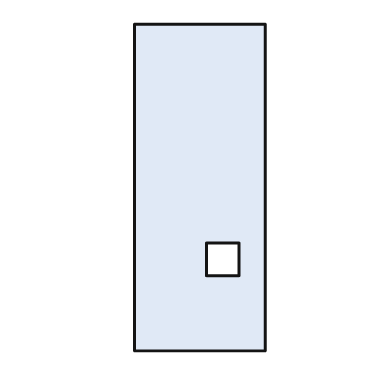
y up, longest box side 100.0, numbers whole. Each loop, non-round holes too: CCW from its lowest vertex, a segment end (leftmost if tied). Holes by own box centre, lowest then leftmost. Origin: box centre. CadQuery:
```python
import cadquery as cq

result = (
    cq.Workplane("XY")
    .moveTo(-20.0, -50.0)
    .lineTo(20.0, -50.0)
    .lineTo(20.0, 50.0)
    .lineTo(-20.0, 50.0)
    .close()
    .moveTo(2.0, -27.0)
    .lineTo(12.0, -27.0)
    .lineTo(12.0, -17.0)
    .lineTo(2.0, -17.0)
    .close()
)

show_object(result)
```